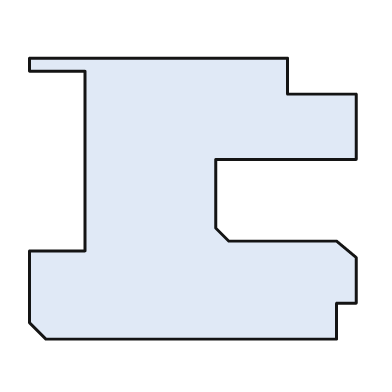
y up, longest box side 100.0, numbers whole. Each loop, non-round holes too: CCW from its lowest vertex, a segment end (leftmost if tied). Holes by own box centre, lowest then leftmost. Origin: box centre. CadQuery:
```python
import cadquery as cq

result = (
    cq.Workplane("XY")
    .moveTo(-45.0, -43.0)
    .lineTo(44.0, -43.0)
    .lineTo(44.0, -32.0)
    .lineTo(50.0, -32.0)
    .lineTo(50.0, -18.0)
    .lineTo(44.0, -13.0)
    .lineTo(11.0, -13.0)
    .lineTo(7.0, -9.0)
    .lineTo(7.0, 12.0)
    .lineTo(50.0, 12.0)
    .lineTo(50.0, 32.0)
    .lineTo(29.0, 32.0)
    .lineTo(29.0, 43.0)
    .lineTo(-50.0, 43.0)
    .lineTo(-50.0, 39.0)
    .lineTo(-33.0, 39.0)
    .lineTo(-33.0, -16.0)
    .lineTo(-50.0, -16.0)
    .lineTo(-50.0, -38.0)
    .close()
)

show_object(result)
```